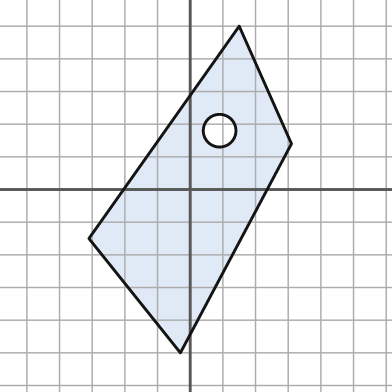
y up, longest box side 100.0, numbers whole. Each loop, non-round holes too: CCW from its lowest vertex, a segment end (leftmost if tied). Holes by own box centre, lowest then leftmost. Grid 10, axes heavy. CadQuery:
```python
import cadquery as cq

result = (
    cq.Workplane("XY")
    .moveTo(-3.0, -50.0)
    .lineTo(31.0, 14.0)
    .lineTo(15.0, 50.0)
    .lineTo(-31.0, -15.0)
    .close()
    .moveTo(9.0, 18.0)
    .circle(5.0)
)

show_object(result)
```